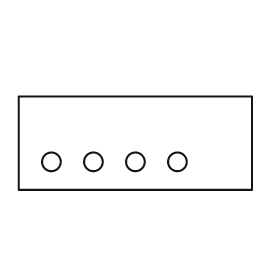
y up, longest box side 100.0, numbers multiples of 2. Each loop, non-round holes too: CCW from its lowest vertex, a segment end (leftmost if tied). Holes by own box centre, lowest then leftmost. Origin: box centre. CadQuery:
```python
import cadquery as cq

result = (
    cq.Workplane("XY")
    .moveTo(-50.0, -20.0)
    .lineTo(50.0, -20.0)
    .lineTo(50.0, 20.0)
    .lineTo(-50.0, 20.0)
    .close()
    .moveTo(-36.0, -8.0)
    .circle(4.0)
    .moveTo(-18.0, -8.0)
    .circle(4.0)
    .moveTo(0.0, -8.0)
    .circle(4.0)
    .moveTo(18.0, -8.0)
    .circle(4.0)
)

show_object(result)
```